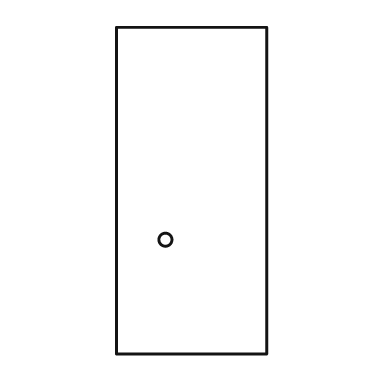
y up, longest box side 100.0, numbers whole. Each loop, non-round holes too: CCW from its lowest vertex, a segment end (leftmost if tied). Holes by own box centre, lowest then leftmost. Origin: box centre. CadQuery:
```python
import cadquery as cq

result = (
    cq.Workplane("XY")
    .moveTo(-23.0, -50.0)
    .lineTo(23.0, -50.0)
    .lineTo(23.0, 50.0)
    .lineTo(-23.0, 50.0)
    .close()
    .moveTo(-8.0, -15.0)
    .circle(2.0)
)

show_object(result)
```